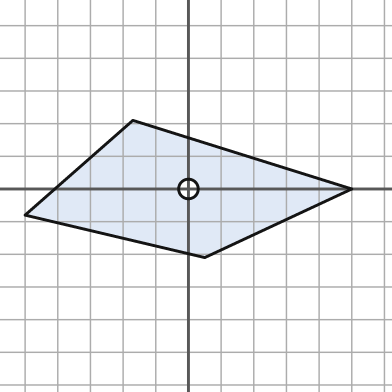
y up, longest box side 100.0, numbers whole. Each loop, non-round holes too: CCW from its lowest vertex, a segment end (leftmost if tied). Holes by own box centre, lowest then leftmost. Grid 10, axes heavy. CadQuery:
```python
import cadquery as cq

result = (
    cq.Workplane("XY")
    .moveTo(5.0, -21.0)
    .lineTo(50.0, 0.0)
    .lineTo(-17.0, 21.0)
    .lineTo(-50.0, -8.0)
    .close()
    .moveTo(0.0, 0.0)
    .circle(3.0)
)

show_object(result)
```